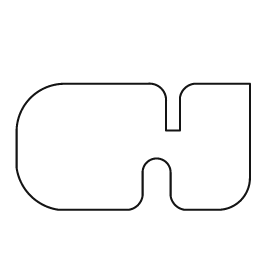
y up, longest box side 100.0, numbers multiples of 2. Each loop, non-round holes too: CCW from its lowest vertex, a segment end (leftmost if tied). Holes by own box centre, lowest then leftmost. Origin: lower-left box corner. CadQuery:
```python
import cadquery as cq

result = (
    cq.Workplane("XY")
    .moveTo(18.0, 0.0)
    .lineTo(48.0, 0.0)
    .threePointArc((52.0, 2.0), (54.0, 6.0))
    .lineTo(54.0, 16.0)
    .threePointArc((60.0, 22.0), (66.0, 16.0))
    .lineTo(66.0, 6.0)
    .threePointArc((68.0, 2.0), (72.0, 0.0))
    .lineTo(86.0, 0.0)
    .threePointArc((96.0, 4.0), (100.0, 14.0))
    .lineTo(100.0, 54.0)
    .lineTo(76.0, 54.0)
    .threePointArc((72.0, 52.0), (70.0, 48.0))
    .lineTo(70.0, 34.0)
    .lineTo(64.0, 34.0)
    .lineTo(64.0, 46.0)
    .threePointArc((62.0, 52.0), (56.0, 54.0))
    .lineTo(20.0, 54.0)
    .threePointArc((6.0, 48.0), (0.0, 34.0))
    .lineTo(0.0, 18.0)
    .threePointArc((6.0, 6.0), (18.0, 0.0))
    .close()
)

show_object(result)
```